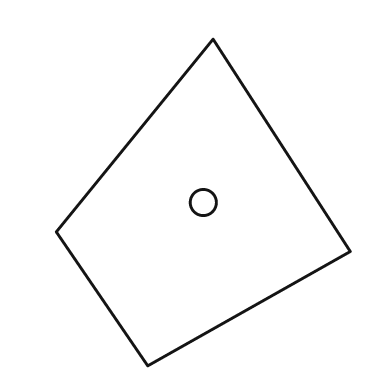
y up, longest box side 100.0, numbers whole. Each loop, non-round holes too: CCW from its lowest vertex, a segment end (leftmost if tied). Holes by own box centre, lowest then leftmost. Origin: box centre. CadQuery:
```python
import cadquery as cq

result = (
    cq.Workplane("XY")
    .moveTo(-17.0, -50.0)
    .lineTo(45.0, -15.0)
    .lineTo(3.0, 50.0)
    .lineTo(-45.0, -9.0)
    .close()
    .moveTo(0.0, 0.0)
    .circle(4.0)
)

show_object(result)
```